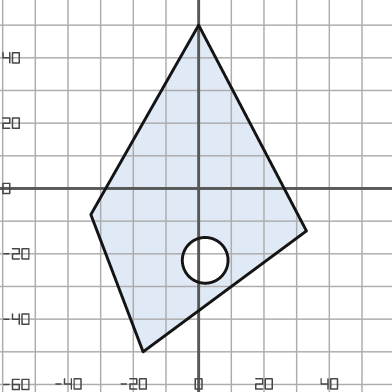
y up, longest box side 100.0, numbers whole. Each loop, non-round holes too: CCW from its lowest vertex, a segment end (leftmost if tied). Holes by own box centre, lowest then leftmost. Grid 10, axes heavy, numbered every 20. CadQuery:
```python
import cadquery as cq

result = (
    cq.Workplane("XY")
    .moveTo(-17.0, -50.0)
    .lineTo(33.0, -13.0)
    .lineTo(0.0, 50.0)
    .lineTo(-33.0, -8.0)
    .close()
    .moveTo(2.0, -22.0)
    .circle(7.0)
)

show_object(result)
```